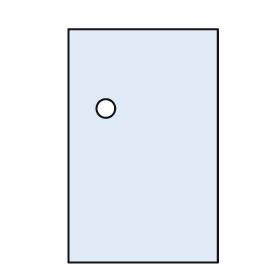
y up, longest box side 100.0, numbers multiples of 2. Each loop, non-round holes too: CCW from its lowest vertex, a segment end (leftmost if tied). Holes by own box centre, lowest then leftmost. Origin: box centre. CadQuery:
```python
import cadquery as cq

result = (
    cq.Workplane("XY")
    .moveTo(-32.0, -50.0)
    .lineTo(32.0, -50.0)
    .lineTo(32.0, 50.0)
    .lineTo(-32.0, 50.0)
    .close()
    .moveTo(-16.0, 16.0)
    .circle(4.0)
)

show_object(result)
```